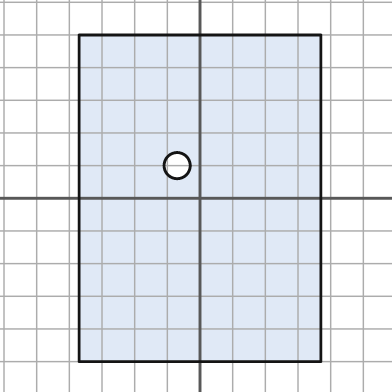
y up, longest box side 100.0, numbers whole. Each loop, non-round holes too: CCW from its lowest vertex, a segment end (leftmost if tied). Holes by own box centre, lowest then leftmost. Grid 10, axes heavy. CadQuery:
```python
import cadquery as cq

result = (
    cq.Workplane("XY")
    .moveTo(-37.0, -50.0)
    .lineTo(37.0, -50.0)
    .lineTo(37.0, 50.0)
    .lineTo(-37.0, 50.0)
    .close()
    .moveTo(-7.0, 10.0)
    .circle(4.0)
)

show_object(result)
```